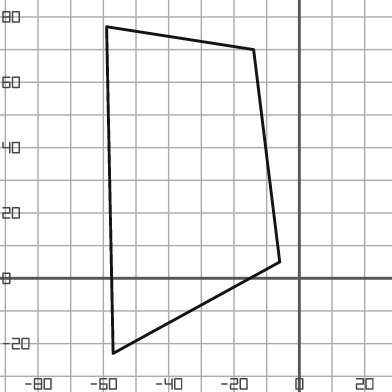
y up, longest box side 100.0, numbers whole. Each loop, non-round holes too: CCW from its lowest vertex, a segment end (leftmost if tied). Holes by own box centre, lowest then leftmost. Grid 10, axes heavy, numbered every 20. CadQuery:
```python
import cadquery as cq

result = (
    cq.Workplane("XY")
    .moveTo(-57.0, -23.0)
    .lineTo(-6.0, 5.0)
    .lineTo(-14.0, 70.0)
    .lineTo(-59.0, 77.0)
    .close()
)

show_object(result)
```